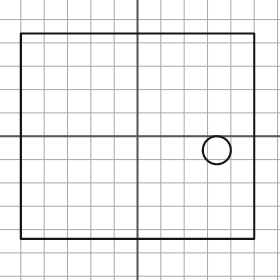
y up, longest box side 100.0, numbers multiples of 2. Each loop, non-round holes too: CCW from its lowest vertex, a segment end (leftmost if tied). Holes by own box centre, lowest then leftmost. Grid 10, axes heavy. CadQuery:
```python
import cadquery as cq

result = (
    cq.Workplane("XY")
    .moveTo(-50.0, -44.0)
    .lineTo(50.0, -44.0)
    .lineTo(50.0, 44.0)
    .lineTo(-50.0, 44.0)
    .close()
    .moveTo(34.0, -6.0)
    .circle(6.0)
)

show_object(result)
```